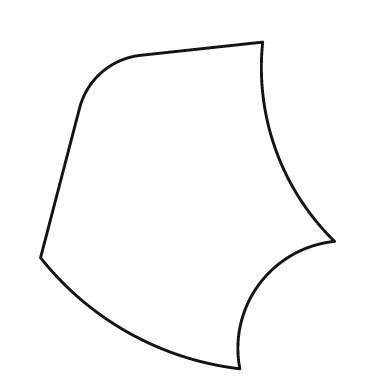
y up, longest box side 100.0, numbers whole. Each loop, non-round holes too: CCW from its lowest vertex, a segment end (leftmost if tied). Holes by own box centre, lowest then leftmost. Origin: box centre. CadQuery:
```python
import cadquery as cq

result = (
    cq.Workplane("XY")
    .moveTo(16.0, -50.0)
    .threePointArc((22.0, -24.0), (45.0, -11.0))
    .threePointArc((27.0, 17.0), (23.0, 50.0))
    .lineTo(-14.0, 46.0)
    .threePointArc((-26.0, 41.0), (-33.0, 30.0))
    .lineTo(-45.0, -16.0)
    .threePointArc((-18.0, -39.0), (16.0, -50.0))
    .close()
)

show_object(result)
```